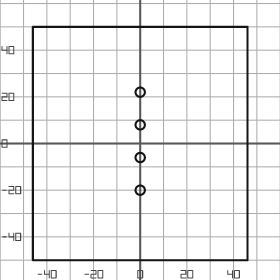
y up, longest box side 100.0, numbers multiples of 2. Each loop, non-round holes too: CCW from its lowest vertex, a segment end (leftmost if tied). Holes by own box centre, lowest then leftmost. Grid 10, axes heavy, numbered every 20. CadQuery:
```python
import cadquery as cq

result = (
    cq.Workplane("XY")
    .moveTo(-46.0, -50.0)
    .lineTo(46.0, -50.0)
    .lineTo(46.0, 50.0)
    .lineTo(-46.0, 50.0)
    .close()
    .moveTo(0.0, -20.0)
    .circle(2.0)
    .moveTo(0.0, -6.0)
    .circle(2.0)
    .moveTo(0.0, 8.0)
    .circle(2.0)
    .moveTo(0.0, 22.0)
    .circle(2.0)
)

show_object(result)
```